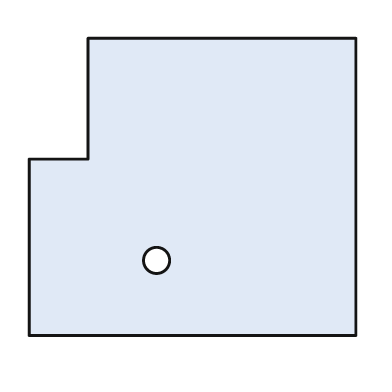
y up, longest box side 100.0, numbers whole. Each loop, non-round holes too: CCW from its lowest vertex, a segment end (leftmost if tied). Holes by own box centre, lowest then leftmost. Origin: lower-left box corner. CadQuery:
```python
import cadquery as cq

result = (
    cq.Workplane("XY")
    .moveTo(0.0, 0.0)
    .lineTo(100.0, 0.0)
    .lineTo(100.0, 91.0)
    .lineTo(18.0, 91.0)
    .lineTo(18.0, 54.0)
    .lineTo(0.0, 54.0)
    .close()
    .moveTo(39.0, 23.0)
    .circle(4.0)
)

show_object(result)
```